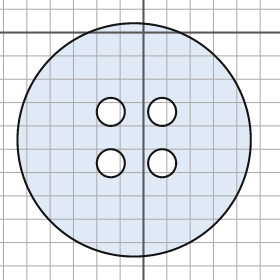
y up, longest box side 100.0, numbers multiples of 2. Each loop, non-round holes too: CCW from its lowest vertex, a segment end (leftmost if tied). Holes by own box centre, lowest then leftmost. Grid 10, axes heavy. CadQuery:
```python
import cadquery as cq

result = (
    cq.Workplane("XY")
    .moveTo(-4.0, -46.0)
    .circle(50.0)
    .moveTo(-14.0, -56.0)
    .circle(6.0)
    .moveTo(8.0, -56.0)
    .circle(6.0)
    .moveTo(-14.0, -34.0)
    .circle(6.0)
    .moveTo(8.0, -34.0)
    .circle(6.0)
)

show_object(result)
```